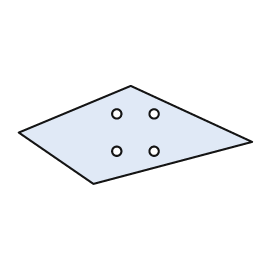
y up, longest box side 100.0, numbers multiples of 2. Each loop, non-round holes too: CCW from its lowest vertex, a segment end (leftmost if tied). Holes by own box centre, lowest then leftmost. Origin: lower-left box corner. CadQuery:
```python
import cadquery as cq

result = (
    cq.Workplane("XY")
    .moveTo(32.0, 0.0)
    .lineTo(100.0, 18.0)
    .lineTo(48.0, 42.0)
    .lineTo(0.0, 22.0)
    .close()
    .moveTo(42.0, 14.0)
    .circle(2.0)
    .moveTo(58.0, 14.0)
    .circle(2.0)
    .moveTo(42.0, 30.0)
    .circle(2.0)
    .moveTo(58.0, 30.0)
    .circle(2.0)
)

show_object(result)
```